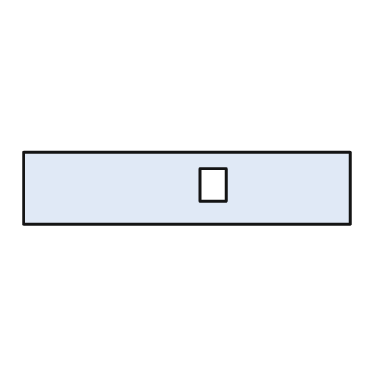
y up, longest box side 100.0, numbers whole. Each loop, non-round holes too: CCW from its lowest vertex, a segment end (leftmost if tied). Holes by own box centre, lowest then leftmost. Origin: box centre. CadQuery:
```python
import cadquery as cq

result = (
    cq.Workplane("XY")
    .moveTo(-50.0, -11.0)
    .lineTo(50.0, -11.0)
    .lineTo(50.0, 11.0)
    .lineTo(-50.0, 11.0)
    .close()
    .moveTo(4.0, -4.0)
    .lineTo(12.0, -4.0)
    .lineTo(12.0, 6.0)
    .lineTo(4.0, 6.0)
    .close()
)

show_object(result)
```